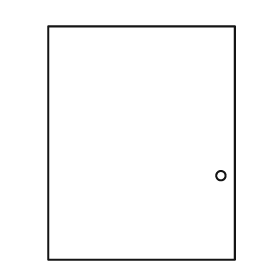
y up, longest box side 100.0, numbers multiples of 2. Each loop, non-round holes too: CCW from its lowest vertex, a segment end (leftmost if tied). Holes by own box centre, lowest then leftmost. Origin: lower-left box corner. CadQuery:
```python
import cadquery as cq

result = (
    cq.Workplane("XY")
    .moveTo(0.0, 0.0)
    .lineTo(80.0, 0.0)
    .lineTo(80.0, 100.0)
    .lineTo(0.0, 100.0)
    .close()
    .moveTo(74.0, 36.0)
    .circle(2.0)
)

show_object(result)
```